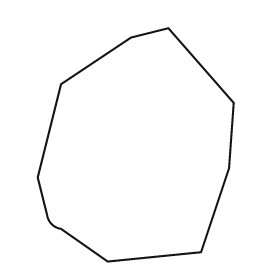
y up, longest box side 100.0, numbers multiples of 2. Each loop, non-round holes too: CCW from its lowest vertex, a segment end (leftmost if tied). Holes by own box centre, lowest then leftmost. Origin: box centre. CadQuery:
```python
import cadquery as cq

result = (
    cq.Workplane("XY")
    .moveTo(-12.0, -50.0)
    .lineTo(28.0, -46.0)
    .lineTo(40.0, -10.0)
    .lineTo(42.0, 18.0)
    .lineTo(14.0, 50.0)
    .lineTo(-2.0, 46.0)
    .lineTo(-32.0, 26.0)
    .lineTo(-42.0, -14.0)
    .lineTo(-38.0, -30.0)
    .threePointArc((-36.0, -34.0), (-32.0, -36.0))
    .close()
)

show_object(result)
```